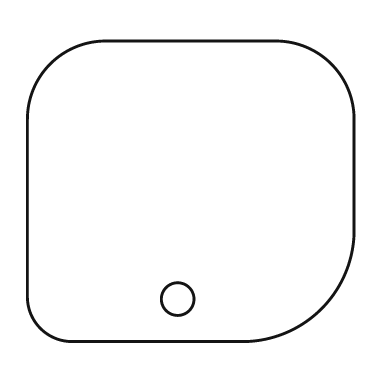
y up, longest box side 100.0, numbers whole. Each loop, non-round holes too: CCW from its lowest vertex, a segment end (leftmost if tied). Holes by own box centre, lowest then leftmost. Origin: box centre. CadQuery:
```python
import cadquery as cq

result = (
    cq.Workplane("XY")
    .moveTo(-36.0, -46.0)
    .lineTo(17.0, -46.0)
    .threePointArc((40.0, -36.0), (50.0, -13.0))
    .lineTo(50.0, 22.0)
    .threePointArc((43.0, 39.0), (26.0, 46.0))
    .lineTo(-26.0, 46.0)
    .threePointArc((-43.0, 39.0), (-50.0, 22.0))
    .lineTo(-50.0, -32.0)
    .threePointArc((-46.0, -42.0), (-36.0, -46.0))
    .close()
    .moveTo(-4.0, -33.0)
    .circle(5.0)
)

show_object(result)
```